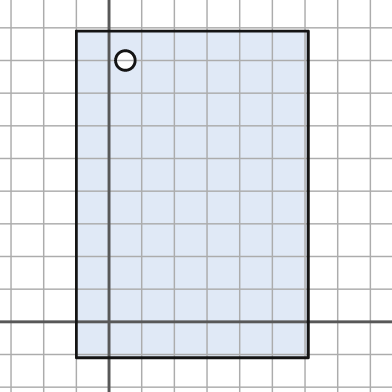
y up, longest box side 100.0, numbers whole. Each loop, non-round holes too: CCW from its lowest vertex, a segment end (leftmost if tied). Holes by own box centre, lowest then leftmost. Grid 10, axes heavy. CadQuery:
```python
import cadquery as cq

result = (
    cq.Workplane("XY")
    .moveTo(-10.0, -11.0)
    .lineTo(61.0, -11.0)
    .lineTo(61.0, 89.0)
    .lineTo(-10.0, 89.0)
    .close()
    .moveTo(5.0, 80.0)
    .circle(3.0)
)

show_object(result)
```